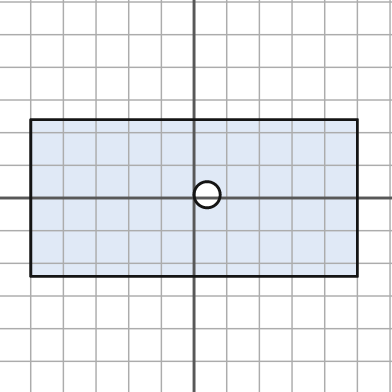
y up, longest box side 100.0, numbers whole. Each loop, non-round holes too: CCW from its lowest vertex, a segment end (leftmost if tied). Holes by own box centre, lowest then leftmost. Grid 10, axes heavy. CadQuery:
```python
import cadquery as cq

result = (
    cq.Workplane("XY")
    .moveTo(-50.0, -24.0)
    .lineTo(50.0, -24.0)
    .lineTo(50.0, 24.0)
    .lineTo(-50.0, 24.0)
    .close()
    .moveTo(4.0, 1.0)
    .circle(4.0)
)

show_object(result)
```